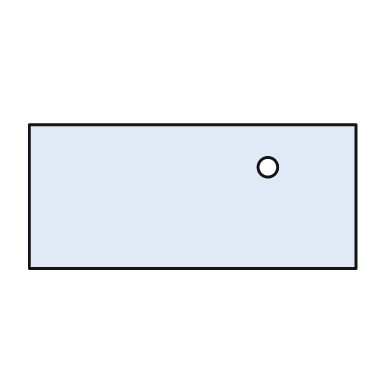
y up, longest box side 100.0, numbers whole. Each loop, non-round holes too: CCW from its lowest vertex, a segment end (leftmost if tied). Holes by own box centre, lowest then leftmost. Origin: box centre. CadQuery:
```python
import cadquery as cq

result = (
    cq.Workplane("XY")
    .moveTo(-50.0, -22.0)
    .lineTo(50.0, -22.0)
    .lineTo(50.0, 22.0)
    .lineTo(-50.0, 22.0)
    .close()
    .moveTo(23.0, 9.0)
    .circle(3.0)
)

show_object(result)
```